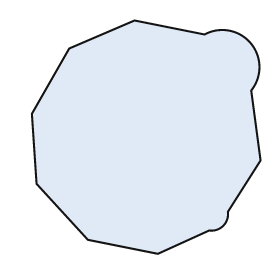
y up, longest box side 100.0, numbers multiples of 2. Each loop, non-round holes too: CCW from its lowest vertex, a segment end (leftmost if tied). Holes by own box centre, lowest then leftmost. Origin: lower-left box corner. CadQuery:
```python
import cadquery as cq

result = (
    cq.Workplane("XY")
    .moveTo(54.0, 0.0)
    .lineTo(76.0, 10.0)
    .threePointArc((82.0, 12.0), (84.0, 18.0))
    .lineTo(98.0, 40.0)
    .lineTo(94.0, 70.0)
    .threePointArc((94.0, 90.0), (74.0, 94.0))
    .lineTo(44.0, 100.0)
    .lineTo(16.0, 88.0)
    .lineTo(0.0, 60.0)
    .lineTo(2.0, 30.0)
    .lineTo(24.0, 6.0)
    .close()
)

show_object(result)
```